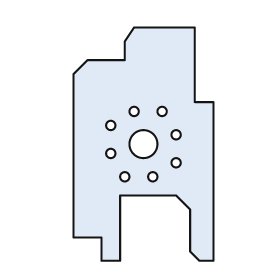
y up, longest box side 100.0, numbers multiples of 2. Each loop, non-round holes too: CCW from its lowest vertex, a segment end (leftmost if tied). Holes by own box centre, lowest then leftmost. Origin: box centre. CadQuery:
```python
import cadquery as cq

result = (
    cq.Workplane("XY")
    .moveTo(-18.0, -50.0)
    .lineTo(-10.0, -50.0)
    .lineTo(-10.0, -22.0)
    .lineTo(14.0, -22.0)
    .lineTo(20.0, -28.0)
    .lineTo(20.0, -46.0)
    .lineTo(24.0, -50.0)
    .lineTo(30.0, -50.0)
    .lineTo(30.0, 18.0)
    .lineTo(22.0, 18.0)
    .lineTo(22.0, 50.0)
    .lineTo(-4.0, 50.0)
    .lineTo(-8.0, 44.0)
    .lineTo(-8.0, 36.0)
    .lineTo(-24.0, 36.0)
    .lineTo(-30.0, 30.0)
    .lineTo(-30.0, -40.0)
    .lineTo(-18.0, -40.0)
    .close()
    .moveTo(-8.0, -14.0)
    .circle(2.0)
    .moveTo(4.0, -14.0)
    .circle(2.0)
    .moveTo(14.0, -8.0)
    .circle(2.0)
    .moveTo(-14.0, -4.0)
    .circle(2.0)
    .moveTo(0.0, 0.0)
    .circle(6.0)
    .moveTo(14.0, 4.0)
    .circle(2.0)
    .moveTo(-14.0, 8.0)
    .circle(2.0)
    .moveTo(-4.0, 14.0)
    .circle(2.0)
    .moveTo(8.0, 14.0)
    .circle(2.0)
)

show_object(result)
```